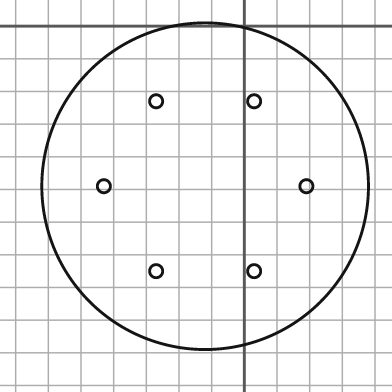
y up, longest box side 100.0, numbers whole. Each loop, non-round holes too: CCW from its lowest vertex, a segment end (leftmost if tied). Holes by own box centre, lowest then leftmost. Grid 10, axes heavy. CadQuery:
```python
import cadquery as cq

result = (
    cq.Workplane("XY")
    .moveTo(-12.0, -49.0)
    .circle(50.0)
    .moveTo(-27.0, -75.0)
    .circle(2.0)
    .moveTo(3.0, -75.0)
    .circle(2.0)
    .moveTo(-43.0, -49.0)
    .circle(2.0)
    .moveTo(19.0, -49.0)
    .circle(2.0)
    .moveTo(-27.0, -23.0)
    .circle(2.0)
    .moveTo(3.0, -23.0)
    .circle(2.0)
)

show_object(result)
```